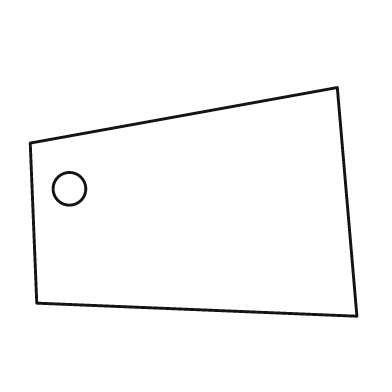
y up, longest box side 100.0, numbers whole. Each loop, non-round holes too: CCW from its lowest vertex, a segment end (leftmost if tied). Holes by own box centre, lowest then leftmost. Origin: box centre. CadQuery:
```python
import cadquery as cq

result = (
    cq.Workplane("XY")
    .moveTo(50.0, -35.0)
    .lineTo(44.0, 35.0)
    .lineTo(-50.0, 18.0)
    .lineTo(-48.0, -31.0)
    .close()
    .moveTo(-38.0, 4.0)
    .circle(5.0)
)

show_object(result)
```